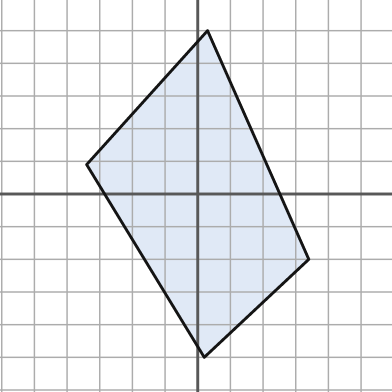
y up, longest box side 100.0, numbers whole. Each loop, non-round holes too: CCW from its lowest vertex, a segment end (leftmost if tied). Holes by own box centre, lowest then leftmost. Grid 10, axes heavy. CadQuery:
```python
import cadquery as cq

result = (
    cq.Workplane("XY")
    .moveTo(2.0, -50.0)
    .lineTo(34.0, -20.0)
    .lineTo(3.0, 50.0)
    .lineTo(-34.0, 9.0)
    .close()
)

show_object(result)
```